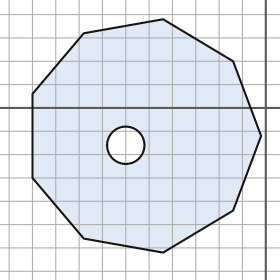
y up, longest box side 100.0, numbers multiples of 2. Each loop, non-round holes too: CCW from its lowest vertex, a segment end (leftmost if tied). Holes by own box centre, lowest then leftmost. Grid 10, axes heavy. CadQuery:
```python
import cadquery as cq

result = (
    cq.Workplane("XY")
    .moveTo(-44.0, -62.0)
    .lineTo(-14.0, -44.0)
    .lineTo(-2.0, -12.0)
    .lineTo(-14.0, 20.0)
    .lineTo(-44.0, 38.0)
    .lineTo(-78.0, 32.0)
    .lineTo(-100.0, 6.0)
    .lineTo(-100.0, -30.0)
    .lineTo(-78.0, -56.0)
    .close()
    .moveTo(-60.0, -16.0)
    .circle(8.0)
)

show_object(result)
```